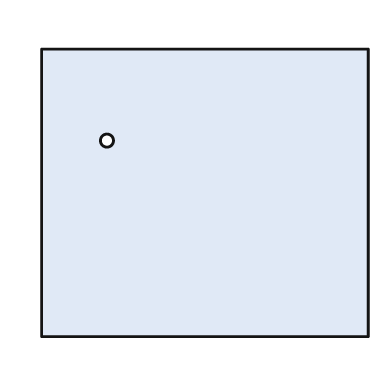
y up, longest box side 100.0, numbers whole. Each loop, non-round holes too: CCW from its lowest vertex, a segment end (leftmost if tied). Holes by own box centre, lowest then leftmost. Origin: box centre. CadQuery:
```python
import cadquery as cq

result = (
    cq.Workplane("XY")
    .moveTo(-50.0, -44.0)
    .lineTo(50.0, -44.0)
    .lineTo(50.0, 44.0)
    .lineTo(-50.0, 44.0)
    .close()
    .moveTo(-30.0, 16.0)
    .circle(2.0)
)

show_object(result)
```